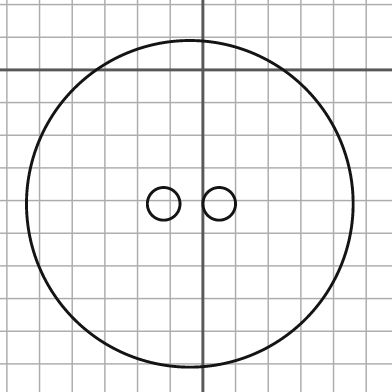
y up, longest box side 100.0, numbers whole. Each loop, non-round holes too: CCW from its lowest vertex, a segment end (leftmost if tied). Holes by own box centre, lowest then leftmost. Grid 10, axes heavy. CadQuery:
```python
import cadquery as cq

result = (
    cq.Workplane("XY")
    .moveTo(-4.0, -41.0)
    .circle(50.0)
    .moveTo(-12.0, -41.0)
    .circle(5.0)
    .moveTo(5.0, -41.0)
    .circle(5.0)
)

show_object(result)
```